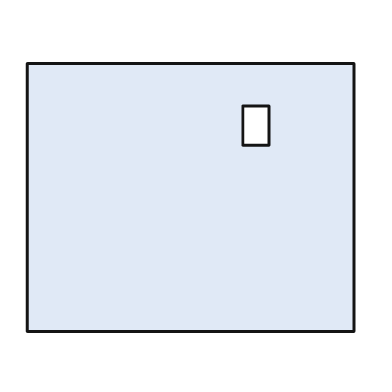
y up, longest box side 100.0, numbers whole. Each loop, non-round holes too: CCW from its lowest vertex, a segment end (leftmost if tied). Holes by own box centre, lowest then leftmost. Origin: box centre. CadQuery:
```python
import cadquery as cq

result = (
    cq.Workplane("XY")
    .moveTo(-50.0, -41.0)
    .lineTo(50.0, -41.0)
    .lineTo(50.0, 41.0)
    .lineTo(-50.0, 41.0)
    .close()
    .moveTo(16.0, 16.0)
    .lineTo(24.0, 16.0)
    .lineTo(24.0, 28.0)
    .lineTo(16.0, 28.0)
    .close()
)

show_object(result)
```